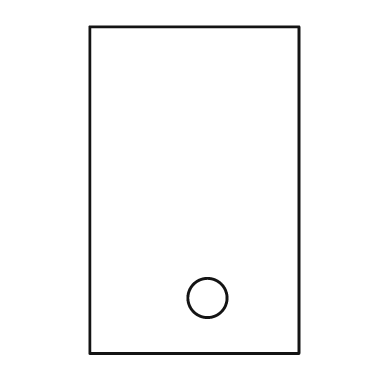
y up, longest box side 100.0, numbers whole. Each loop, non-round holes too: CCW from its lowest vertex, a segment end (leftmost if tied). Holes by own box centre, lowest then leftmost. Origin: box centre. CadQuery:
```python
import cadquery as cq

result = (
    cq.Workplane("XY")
    .moveTo(-32.0, -50.0)
    .lineTo(32.0, -50.0)
    .lineTo(32.0, 50.0)
    .lineTo(-32.0, 50.0)
    .close()
    .moveTo(4.0, -33.0)
    .circle(6.0)
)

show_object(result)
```